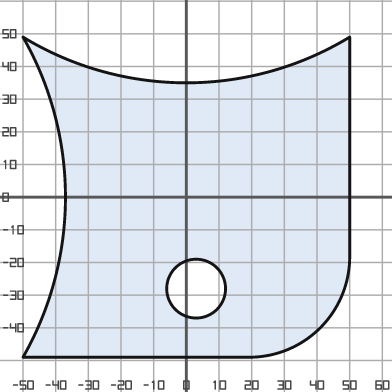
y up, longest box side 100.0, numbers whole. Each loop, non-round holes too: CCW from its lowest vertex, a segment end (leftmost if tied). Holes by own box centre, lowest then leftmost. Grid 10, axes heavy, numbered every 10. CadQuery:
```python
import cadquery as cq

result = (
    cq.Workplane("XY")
    .moveTo(-50.0, -49.0)
    .lineTo(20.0, -49.0)
    .threePointArc((41.0, -40.0), (50.0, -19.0))
    .lineTo(50.0, 49.0)
    .threePointArc((0.0, 35.0), (-50.0, 49.0))
    .threePointArc((-37.0, 0.0), (-50.0, -49.0))
    .close()
    .moveTo(3.0, -28.0)
    .circle(9.0)
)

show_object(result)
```